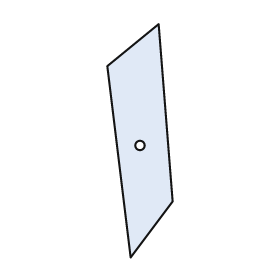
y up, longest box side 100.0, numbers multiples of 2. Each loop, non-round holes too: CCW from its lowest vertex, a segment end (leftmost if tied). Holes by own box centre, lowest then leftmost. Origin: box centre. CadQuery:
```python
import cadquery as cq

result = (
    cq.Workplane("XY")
    .moveTo(-4.0, -50.0)
    .lineTo(14.0, -26.0)
    .lineTo(8.0, 50.0)
    .lineTo(-14.0, 32.0)
    .close()
    .moveTo(0.0, -2.0)
    .circle(2.0)
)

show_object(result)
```